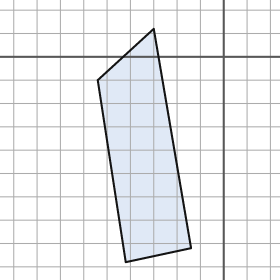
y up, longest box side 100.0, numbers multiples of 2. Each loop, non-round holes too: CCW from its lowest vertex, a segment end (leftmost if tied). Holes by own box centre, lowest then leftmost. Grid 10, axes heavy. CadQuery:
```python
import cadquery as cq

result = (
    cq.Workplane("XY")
    .moveTo(-42.0, -88.0)
    .lineTo(-14.0, -82.0)
    .lineTo(-30.0, 12.0)
    .lineTo(-54.0, -10.0)
    .close()
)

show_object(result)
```